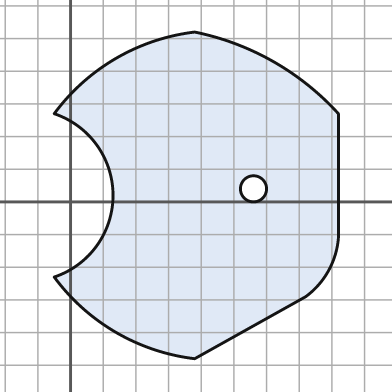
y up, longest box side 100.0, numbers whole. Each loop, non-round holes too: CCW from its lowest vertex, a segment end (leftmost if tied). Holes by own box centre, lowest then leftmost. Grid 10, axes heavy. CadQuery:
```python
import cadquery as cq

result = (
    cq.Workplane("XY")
    .moveTo(38.0, -48.0)
    .lineTo(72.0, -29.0)
    .threePointArc((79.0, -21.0), (82.0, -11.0))
    .lineTo(82.0, 27.0)
    .threePointArc((62.0, 43.0), (38.0, 52.0))
    .threePointArc((14.0, 44.0), (-5.0, 27.0))
    .threePointArc((13.0, 2.0), (-5.0, -23.0))
    .threePointArc((14.0, -40.0), (38.0, -48.0))
    .close()
    .moveTo(56.0, 4.0)
    .circle(4.0)
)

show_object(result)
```